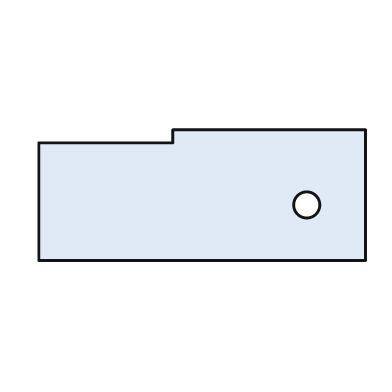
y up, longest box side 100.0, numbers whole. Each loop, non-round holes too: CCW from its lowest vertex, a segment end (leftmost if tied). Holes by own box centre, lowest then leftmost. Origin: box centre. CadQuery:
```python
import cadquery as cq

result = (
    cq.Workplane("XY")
    .moveTo(-50.0, -20.0)
    .lineTo(50.0, -20.0)
    .lineTo(50.0, 20.0)
    .lineTo(-9.0, 20.0)
    .lineTo(-9.0, 16.0)
    .lineTo(-50.0, 16.0)
    .close()
    .moveTo(32.0, -3.0)
    .circle(4.0)
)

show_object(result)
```